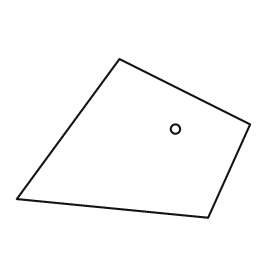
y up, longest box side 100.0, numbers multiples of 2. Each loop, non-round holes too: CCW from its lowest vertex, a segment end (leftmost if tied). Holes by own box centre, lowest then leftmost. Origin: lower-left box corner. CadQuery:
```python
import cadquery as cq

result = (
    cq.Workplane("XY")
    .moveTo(82.0, 0.0)
    .lineTo(100.0, 40.0)
    .lineTo(44.0, 68.0)
    .lineTo(0.0, 8.0)
    .close()
    .moveTo(68.0, 38.0)
    .circle(2.0)
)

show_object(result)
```